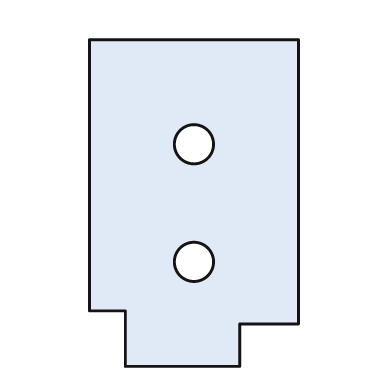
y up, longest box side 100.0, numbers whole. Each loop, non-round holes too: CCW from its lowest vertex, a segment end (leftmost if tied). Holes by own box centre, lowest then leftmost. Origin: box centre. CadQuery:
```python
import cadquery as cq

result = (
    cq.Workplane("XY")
    .moveTo(-21.0, -50.0)
    .lineTo(14.0, -50.0)
    .lineTo(14.0, -37.0)
    .lineTo(32.0, -37.0)
    .lineTo(32.0, 50.0)
    .lineTo(-32.0, 50.0)
    .lineTo(-32.0, -33.0)
    .lineTo(-21.0, -33.0)
    .close()
    .moveTo(0.0, -18.0)
    .circle(6.0)
    .moveTo(0.0, 18.0)
    .circle(6.0)
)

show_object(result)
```